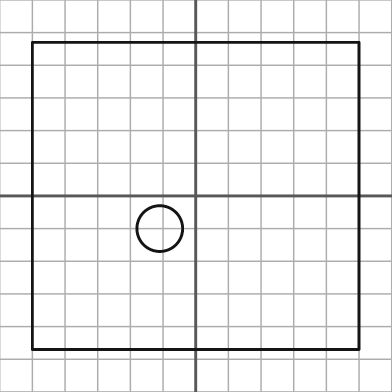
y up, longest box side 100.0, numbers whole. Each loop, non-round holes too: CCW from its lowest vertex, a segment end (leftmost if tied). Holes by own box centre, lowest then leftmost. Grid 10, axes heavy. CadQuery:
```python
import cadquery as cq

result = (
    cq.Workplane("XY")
    .moveTo(-50.0, -47.0)
    .lineTo(50.0, -47.0)
    .lineTo(50.0, 47.0)
    .lineTo(-50.0, 47.0)
    .close()
    .moveTo(-11.0, -10.0)
    .circle(7.0)
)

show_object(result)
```